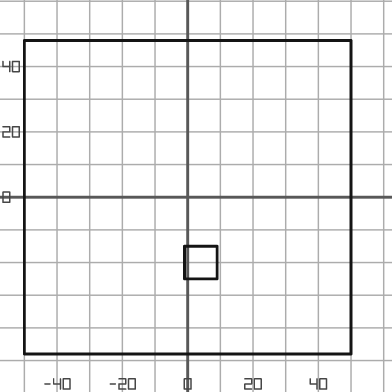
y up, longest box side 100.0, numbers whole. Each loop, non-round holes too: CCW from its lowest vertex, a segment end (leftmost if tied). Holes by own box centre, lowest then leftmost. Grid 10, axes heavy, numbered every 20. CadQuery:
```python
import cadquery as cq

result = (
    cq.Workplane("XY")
    .moveTo(-50.0, -48.0)
    .lineTo(50.0, -48.0)
    .lineTo(50.0, 48.0)
    .lineTo(-50.0, 48.0)
    .close()
    .moveTo(-1.0, -25.0)
    .lineTo(9.0, -25.0)
    .lineTo(9.0, -15.0)
    .lineTo(-1.0, -15.0)
    .close()
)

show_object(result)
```